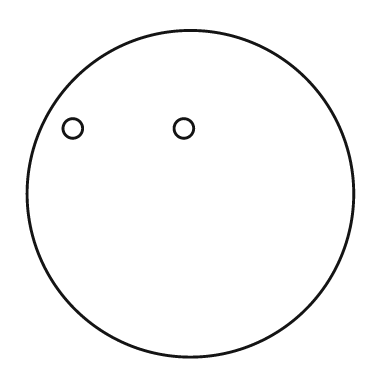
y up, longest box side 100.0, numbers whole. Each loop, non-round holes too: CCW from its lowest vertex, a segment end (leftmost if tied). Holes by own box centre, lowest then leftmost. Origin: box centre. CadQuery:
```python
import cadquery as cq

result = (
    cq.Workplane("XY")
    .moveTo(0.0, 0.0)
    .circle(50.0)
    .moveTo(-36.0, 20.0)
    .circle(3.0)
    .moveTo(-2.0, 20.0)
    .circle(3.0)
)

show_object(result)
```